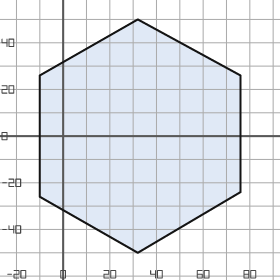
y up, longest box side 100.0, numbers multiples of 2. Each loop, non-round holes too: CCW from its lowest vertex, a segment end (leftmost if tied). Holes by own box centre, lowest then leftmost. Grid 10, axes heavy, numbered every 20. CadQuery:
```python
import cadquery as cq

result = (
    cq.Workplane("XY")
    .moveTo(32.0, -50.0)
    .lineTo(76.0, -24.0)
    .lineTo(76.0, 26.0)
    .lineTo(32.0, 50.0)
    .lineTo(-10.0, 26.0)
    .lineTo(-10.0, -26.0)
    .close()
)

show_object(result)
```